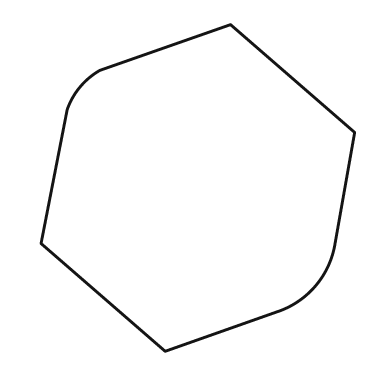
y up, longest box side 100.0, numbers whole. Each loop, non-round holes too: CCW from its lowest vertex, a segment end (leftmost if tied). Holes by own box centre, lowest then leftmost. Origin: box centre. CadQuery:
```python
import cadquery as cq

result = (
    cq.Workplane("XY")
    .moveTo(-10.0, -50.0)
    .lineTo(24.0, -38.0)
    .threePointArc((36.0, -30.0), (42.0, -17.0))
    .lineTo(48.0, 17.0)
    .lineTo(10.0, 50.0)
    .lineTo(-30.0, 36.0)
    .threePointArc((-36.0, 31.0), (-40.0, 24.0))
    .lineTo(-48.0, -17.0)
    .close()
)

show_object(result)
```